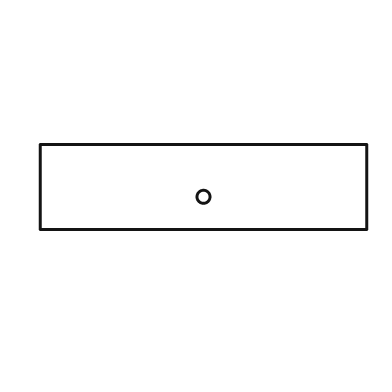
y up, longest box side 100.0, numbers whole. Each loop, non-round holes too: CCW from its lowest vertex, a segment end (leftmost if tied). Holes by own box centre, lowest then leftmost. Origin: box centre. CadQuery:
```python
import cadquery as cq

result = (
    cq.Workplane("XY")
    .moveTo(-50.0, -13.0)
    .lineTo(50.0, -13.0)
    .lineTo(50.0, 13.0)
    .lineTo(-50.0, 13.0)
    .close()
    .moveTo(0.0, -3.0)
    .circle(2.0)
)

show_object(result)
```